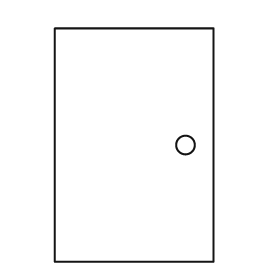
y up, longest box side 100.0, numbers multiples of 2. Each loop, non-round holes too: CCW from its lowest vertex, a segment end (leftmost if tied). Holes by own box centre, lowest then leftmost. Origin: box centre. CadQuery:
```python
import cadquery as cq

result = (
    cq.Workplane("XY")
    .moveTo(-34.0, -50.0)
    .lineTo(34.0, -50.0)
    .lineTo(34.0, 50.0)
    .lineTo(-34.0, 50.0)
    .close()
    .moveTo(22.0, 0.0)
    .circle(4.0)
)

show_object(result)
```